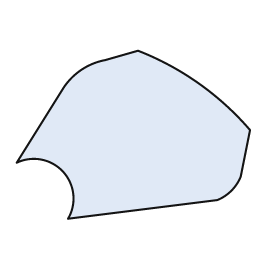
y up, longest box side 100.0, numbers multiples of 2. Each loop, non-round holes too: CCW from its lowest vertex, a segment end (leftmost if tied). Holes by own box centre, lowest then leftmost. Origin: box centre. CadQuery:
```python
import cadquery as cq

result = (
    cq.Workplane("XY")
    .moveTo(-28.0, -36.0)
    .lineTo(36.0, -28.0)
    .threePointArc((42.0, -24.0), (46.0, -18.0))
    .lineTo(50.0, 2.0)
    .threePointArc((28.0, 22.0), (2.0, 36.0))
    .lineTo(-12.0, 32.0)
    .threePointArc((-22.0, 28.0), (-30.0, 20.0))
    .lineTo(-50.0, -12.0)
    .threePointArc((-30.0, -16.0), (-28.0, -36.0))
    .close()
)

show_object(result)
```